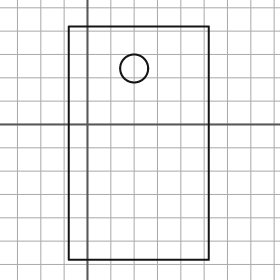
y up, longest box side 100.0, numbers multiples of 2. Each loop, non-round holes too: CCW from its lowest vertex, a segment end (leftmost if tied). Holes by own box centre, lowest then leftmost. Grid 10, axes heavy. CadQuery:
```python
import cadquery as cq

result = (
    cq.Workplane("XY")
    .moveTo(-8.0, -58.0)
    .lineTo(52.0, -58.0)
    .lineTo(52.0, 42.0)
    .lineTo(-8.0, 42.0)
    .close()
    .moveTo(20.0, 24.0)
    .circle(6.0)
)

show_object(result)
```